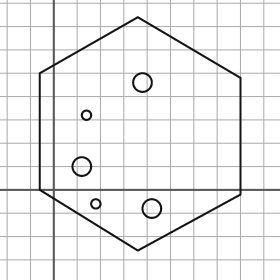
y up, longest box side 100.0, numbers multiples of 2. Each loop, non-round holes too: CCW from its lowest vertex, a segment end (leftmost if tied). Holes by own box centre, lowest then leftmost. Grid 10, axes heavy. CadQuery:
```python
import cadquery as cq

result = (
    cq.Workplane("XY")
    .moveTo(36.0, -26.0)
    .lineTo(80.0, -2.0)
    .lineTo(80.0, 48.0)
    .lineTo(36.0, 74.0)
    .lineTo(-6.0, 50.0)
    .lineTo(-6.0, 0.0)
    .close()
    .moveTo(42.0, -8.0)
    .circle(4.0)
    .moveTo(18.0, -6.0)
    .circle(2.0)
    .moveTo(12.0, 10.0)
    .circle(4.0)
    .moveTo(14.0, 32.0)
    .circle(2.0)
    .moveTo(38.0, 46.0)
    .circle(4.0)
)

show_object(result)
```